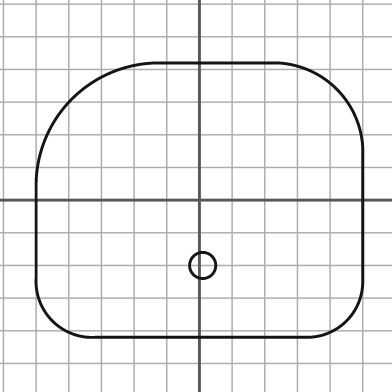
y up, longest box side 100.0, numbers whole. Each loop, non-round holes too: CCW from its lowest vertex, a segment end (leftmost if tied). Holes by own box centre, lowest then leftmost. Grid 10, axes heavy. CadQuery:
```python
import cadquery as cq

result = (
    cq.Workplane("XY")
    .moveTo(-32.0, -42.0)
    .lineTo(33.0, -42.0)
    .threePointArc((45.0, -37.0), (50.0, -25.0))
    .lineTo(50.0, 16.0)
    .threePointArc((42.0, 34.0), (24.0, 42.0))
    .lineTo(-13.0, 42.0)
    .threePointArc((-39.0, 31.0), (-50.0, 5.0))
    .lineTo(-50.0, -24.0)
    .threePointArc((-45.0, -37.0), (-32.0, -42.0))
    .close()
    .moveTo(1.0, -20.0)
    .circle(4.0)
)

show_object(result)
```